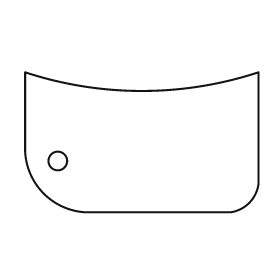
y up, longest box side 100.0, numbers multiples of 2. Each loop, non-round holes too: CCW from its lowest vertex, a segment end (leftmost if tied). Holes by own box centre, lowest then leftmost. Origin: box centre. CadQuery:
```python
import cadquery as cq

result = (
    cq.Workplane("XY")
    .moveTo(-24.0, -30.0)
    .lineTo(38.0, -30.0)
    .threePointArc((46.0, -26.0), (50.0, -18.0))
    .lineTo(50.0, 30.0)
    .threePointArc((0.0, 22.0), (-50.0, 30.0))
    .lineTo(-50.0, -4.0)
    .threePointArc((-42.0, -22.0), (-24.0, -30.0))
    .close()
    .moveTo(-36.0, -8.0)
    .circle(4.0)
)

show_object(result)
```